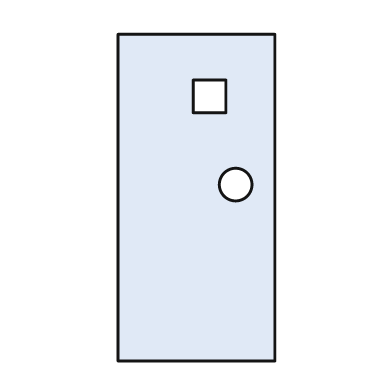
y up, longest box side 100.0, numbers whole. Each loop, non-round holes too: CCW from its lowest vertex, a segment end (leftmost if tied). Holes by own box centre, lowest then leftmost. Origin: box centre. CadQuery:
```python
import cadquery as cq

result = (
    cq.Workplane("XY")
    .moveTo(-24.0, -50.0)
    .lineTo(24.0, -50.0)
    .lineTo(24.0, 50.0)
    .lineTo(-24.0, 50.0)
    .close()
    .moveTo(12.0, 4.0)
    .circle(5.0)
    .moveTo(-1.0, 26.0)
    .lineTo(9.0, 26.0)
    .lineTo(9.0, 36.0)
    .lineTo(-1.0, 36.0)
    .close()
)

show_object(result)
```